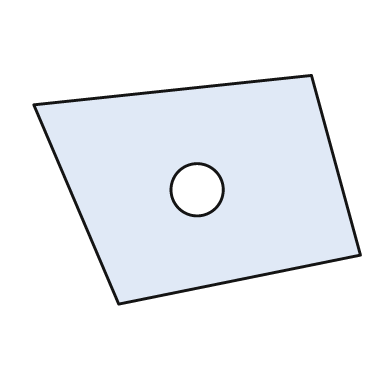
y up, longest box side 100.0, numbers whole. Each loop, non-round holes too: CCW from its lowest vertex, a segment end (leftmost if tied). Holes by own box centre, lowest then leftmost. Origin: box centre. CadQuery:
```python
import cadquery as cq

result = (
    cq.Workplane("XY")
    .moveTo(-24.0, -35.0)
    .lineTo(50.0, -20.0)
    .lineTo(35.0, 35.0)
    .lineTo(-50.0, 26.0)
    .close()
    .moveTo(0.0, 0.0)
    .circle(8.0)
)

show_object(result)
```